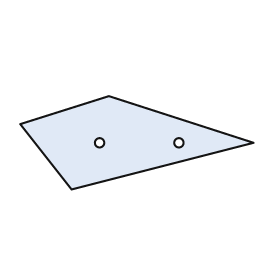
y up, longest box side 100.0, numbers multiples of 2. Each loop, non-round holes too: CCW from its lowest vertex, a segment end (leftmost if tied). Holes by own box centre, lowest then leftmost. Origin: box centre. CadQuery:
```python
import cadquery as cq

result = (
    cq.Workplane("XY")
    .moveTo(-28.0, -20.0)
    .lineTo(50.0, 0.0)
    .lineTo(-12.0, 20.0)
    .lineTo(-50.0, 8.0)
    .close()
    .moveTo(-16.0, 0.0)
    .circle(2.0)
    .moveTo(18.0, 0.0)
    .circle(2.0)
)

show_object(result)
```